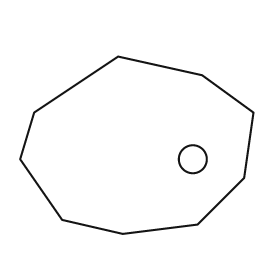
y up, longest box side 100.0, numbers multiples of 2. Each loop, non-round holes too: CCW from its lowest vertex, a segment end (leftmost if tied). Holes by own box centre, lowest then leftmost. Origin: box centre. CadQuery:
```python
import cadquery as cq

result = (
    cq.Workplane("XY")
    .moveTo(-6.0, -38.0)
    .lineTo(26.0, -34.0)
    .lineTo(46.0, -14.0)
    .lineTo(50.0, 14.0)
    .lineTo(28.0, 30.0)
    .lineTo(-8.0, 38.0)
    .lineTo(-44.0, 14.0)
    .lineTo(-50.0, -6.0)
    .lineTo(-32.0, -32.0)
    .close()
    .moveTo(24.0, -6.0)
    .circle(6.0)
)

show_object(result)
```